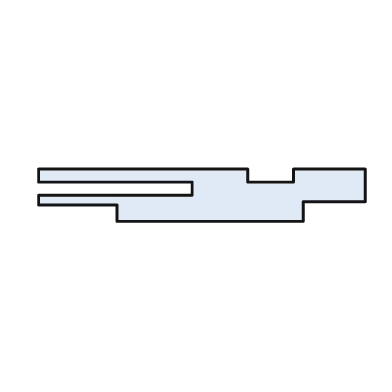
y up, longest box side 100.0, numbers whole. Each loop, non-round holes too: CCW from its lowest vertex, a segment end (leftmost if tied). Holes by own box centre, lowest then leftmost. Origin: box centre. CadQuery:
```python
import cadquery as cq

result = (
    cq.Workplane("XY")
    .moveTo(-26.0, -8.0)
    .lineTo(31.0, -8.0)
    .lineTo(31.0, -2.0)
    .lineTo(50.0, -2.0)
    .lineTo(50.0, 8.0)
    .lineTo(28.0, 8.0)
    .lineTo(28.0, 4.0)
    .lineTo(14.0, 4.0)
    .lineTo(14.0, 8.0)
    .lineTo(-50.0, 8.0)
    .lineTo(-50.0, 4.0)
    .lineTo(-3.0, 4.0)
    .lineTo(-3.0, 0.0)
    .lineTo(-50.0, 0.0)
    .lineTo(-50.0, -3.0)
    .lineTo(-26.0, -3.0)
    .close()
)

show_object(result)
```